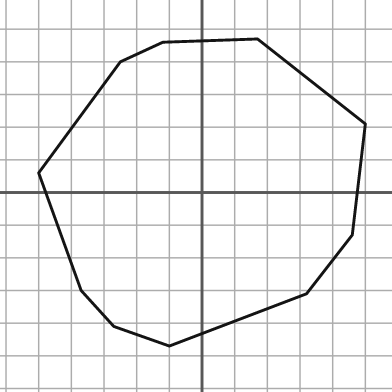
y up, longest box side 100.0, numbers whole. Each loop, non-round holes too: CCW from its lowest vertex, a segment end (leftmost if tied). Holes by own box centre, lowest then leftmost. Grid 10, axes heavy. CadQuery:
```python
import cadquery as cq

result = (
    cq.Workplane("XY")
    .moveTo(-10.0, -47.0)
    .lineTo(32.0, -31.0)
    .lineTo(46.0, -13.0)
    .lineTo(50.0, 21.0)
    .lineTo(17.0, 47.0)
    .lineTo(-12.0, 46.0)
    .lineTo(-25.0, 40.0)
    .lineTo(-50.0, 6.0)
    .lineTo(-37.0, -30.0)
    .lineTo(-27.0, -41.0)
    .close()
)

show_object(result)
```